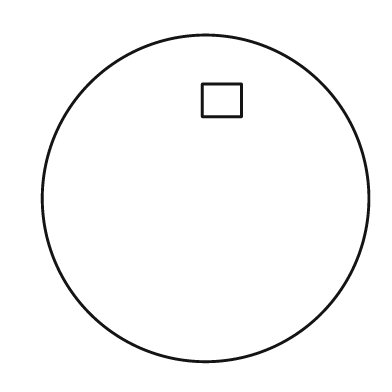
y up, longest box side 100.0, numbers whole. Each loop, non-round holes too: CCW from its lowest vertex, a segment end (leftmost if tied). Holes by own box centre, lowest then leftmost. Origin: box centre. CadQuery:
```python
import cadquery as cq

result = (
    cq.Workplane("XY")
    .moveTo(0.0, 0.0)
    .circle(50.0)
    .moveTo(-1.0, 25.0)
    .lineTo(11.0, 25.0)
    .lineTo(11.0, 35.0)
    .lineTo(-1.0, 35.0)
    .close()
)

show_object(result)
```